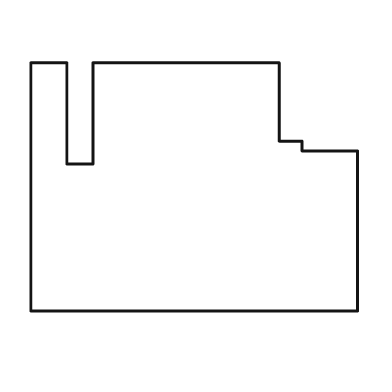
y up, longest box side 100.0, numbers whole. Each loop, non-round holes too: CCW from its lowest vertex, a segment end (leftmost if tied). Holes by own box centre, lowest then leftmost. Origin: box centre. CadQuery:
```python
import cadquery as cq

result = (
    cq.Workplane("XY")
    .moveTo(-50.0, -38.0)
    .lineTo(50.0, -38.0)
    .lineTo(50.0, 11.0)
    .lineTo(33.0, 11.0)
    .lineTo(33.0, 14.0)
    .lineTo(26.0, 14.0)
    .lineTo(26.0, 38.0)
    .lineTo(-31.0, 38.0)
    .lineTo(-31.0, 7.0)
    .lineTo(-39.0, 7.0)
    .lineTo(-39.0, 38.0)
    .lineTo(-50.0, 38.0)
    .close()
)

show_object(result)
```